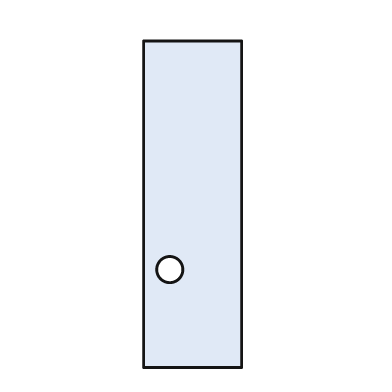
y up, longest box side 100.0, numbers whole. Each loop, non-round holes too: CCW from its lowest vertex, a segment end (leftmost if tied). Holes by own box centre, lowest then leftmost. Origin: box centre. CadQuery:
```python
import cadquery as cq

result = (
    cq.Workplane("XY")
    .moveTo(-15.0, -50.0)
    .lineTo(15.0, -50.0)
    .lineTo(15.0, 50.0)
    .lineTo(-15.0, 50.0)
    .close()
    .moveTo(-7.0, -20.0)
    .circle(4.0)
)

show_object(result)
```